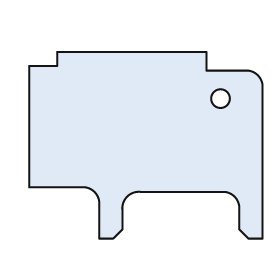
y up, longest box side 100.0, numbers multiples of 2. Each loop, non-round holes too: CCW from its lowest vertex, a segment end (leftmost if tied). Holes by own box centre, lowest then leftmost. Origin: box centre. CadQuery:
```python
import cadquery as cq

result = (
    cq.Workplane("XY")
    .moveTo(-20.0, -40.0)
    .lineTo(-14.0, -40.0)
    .lineTo(-10.0, -36.0)
    .lineTo(-10.0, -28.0)
    .threePointArc((-8.0, -22.0), (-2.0, -20.0))
    .lineTo(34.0, -20.0)
    .threePointArc((38.0, -22.0), (40.0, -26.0))
    .lineTo(40.0, -36.0)
    .lineTo(44.0, -40.0)
    .lineTo(50.0, -40.0)
    .lineTo(50.0, 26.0)
    .threePointArc((48.0, 30.0), (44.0, 32.0))
    .lineTo(26.0, 32.0)
    .lineTo(26.0, 40.0)
    .lineTo(-38.0, 40.0)
    .lineTo(-38.0, 34.0)
    .lineTo(-50.0, 34.0)
    .lineTo(-50.0, -18.0)
    .lineTo(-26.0, -18.0)
    .threePointArc((-22.0, -20.0), (-20.0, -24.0))
    .close()
    .moveTo(32.0, 20.0)
    .circle(4.0)
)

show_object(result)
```